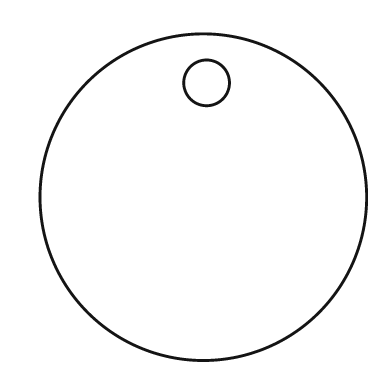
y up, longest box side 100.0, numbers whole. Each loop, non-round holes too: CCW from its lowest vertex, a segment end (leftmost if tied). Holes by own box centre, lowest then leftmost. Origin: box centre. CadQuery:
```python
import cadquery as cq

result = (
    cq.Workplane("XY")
    .moveTo(0.0, 0.0)
    .circle(50.0)
    .moveTo(1.0, 35.0)
    .circle(7.0)
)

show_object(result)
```